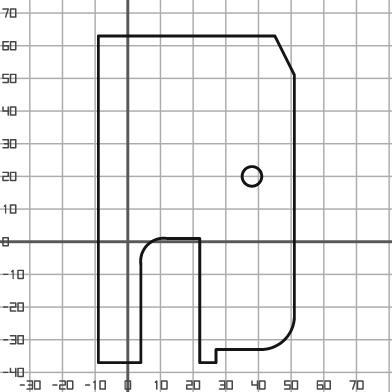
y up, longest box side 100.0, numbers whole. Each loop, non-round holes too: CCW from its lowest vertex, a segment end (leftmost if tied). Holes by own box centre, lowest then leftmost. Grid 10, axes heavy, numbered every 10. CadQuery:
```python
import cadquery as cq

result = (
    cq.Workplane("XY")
    .moveTo(-9.0, -37.0)
    .lineTo(4.0, -37.0)
    .lineTo(4.0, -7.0)
    .threePointArc((6.0, -1.0), (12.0, 1.0))
    .lineTo(22.0, 1.0)
    .lineTo(22.0, -37.0)
    .lineTo(27.0, -37.0)
    .lineTo(27.0, -33.0)
    .lineTo(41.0, -33.0)
    .threePointArc((48.0, -30.0), (51.0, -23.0))
    .lineTo(51.0, 51.0)
    .lineTo(45.0, 63.0)
    .lineTo(-9.0, 63.0)
    .close()
    .moveTo(38.0, 20.0)
    .circle(3.0)
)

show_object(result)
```